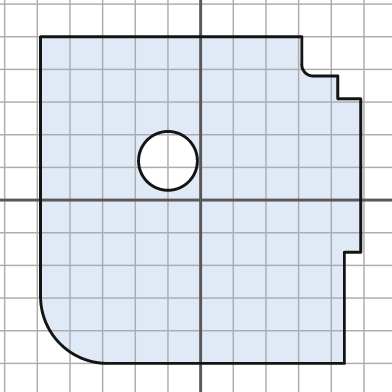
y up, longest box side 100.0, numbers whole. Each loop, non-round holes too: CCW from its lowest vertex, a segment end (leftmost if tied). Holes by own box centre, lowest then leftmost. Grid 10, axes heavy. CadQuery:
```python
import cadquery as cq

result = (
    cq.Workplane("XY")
    .moveTo(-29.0, -50.0)
    .lineTo(44.0, -50.0)
    .lineTo(44.0, -16.0)
    .lineTo(49.0, -16.0)
    .lineTo(49.0, 31.0)
    .lineTo(42.0, 31.0)
    .lineTo(42.0, 38.0)
    .lineTo(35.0, 38.0)
    .threePointArc((32.0, 39.0), (31.0, 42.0))
    .lineTo(31.0, 50.0)
    .lineTo(-49.0, 50.0)
    .lineTo(-49.0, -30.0)
    .threePointArc((-43.0, -44.0), (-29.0, -50.0))
    .close()
    .moveTo(-10.0, 12.0)
    .circle(9.0)
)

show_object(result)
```